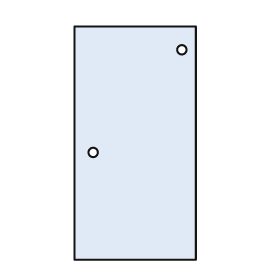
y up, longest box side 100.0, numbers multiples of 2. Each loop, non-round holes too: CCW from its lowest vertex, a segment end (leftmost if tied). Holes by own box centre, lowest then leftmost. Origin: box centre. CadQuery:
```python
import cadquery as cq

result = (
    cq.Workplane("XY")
    .moveTo(-26.0, -50.0)
    .lineTo(26.0, -50.0)
    .lineTo(26.0, 50.0)
    .lineTo(-26.0, 50.0)
    .close()
    .moveTo(-18.0, -4.0)
    .circle(2.0)
    .moveTo(20.0, 40.0)
    .circle(2.0)
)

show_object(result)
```